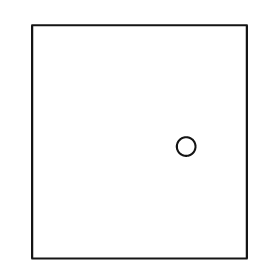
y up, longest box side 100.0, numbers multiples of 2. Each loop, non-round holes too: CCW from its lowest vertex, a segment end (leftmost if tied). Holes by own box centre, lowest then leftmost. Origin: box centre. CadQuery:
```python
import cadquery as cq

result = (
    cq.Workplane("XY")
    .moveTo(-46.0, -50.0)
    .lineTo(46.0, -50.0)
    .lineTo(46.0, 50.0)
    .lineTo(-46.0, 50.0)
    .close()
    .moveTo(20.0, -2.0)
    .circle(4.0)
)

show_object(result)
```